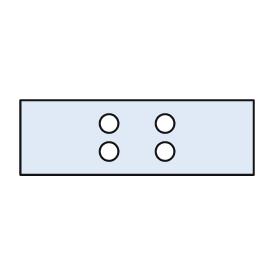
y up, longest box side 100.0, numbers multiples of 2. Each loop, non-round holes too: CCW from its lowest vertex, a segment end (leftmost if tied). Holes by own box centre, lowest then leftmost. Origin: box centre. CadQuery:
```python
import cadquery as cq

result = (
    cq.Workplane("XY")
    .moveTo(-50.0, -16.0)
    .lineTo(50.0, -16.0)
    .lineTo(50.0, 16.0)
    .lineTo(-50.0, 16.0)
    .close()
    .moveTo(-12.0, -6.0)
    .circle(4.0)
    .moveTo(12.0, -6.0)
    .circle(4.0)
    .moveTo(-12.0, 6.0)
    .circle(4.0)
    .moveTo(12.0, 6.0)
    .circle(4.0)
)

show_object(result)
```